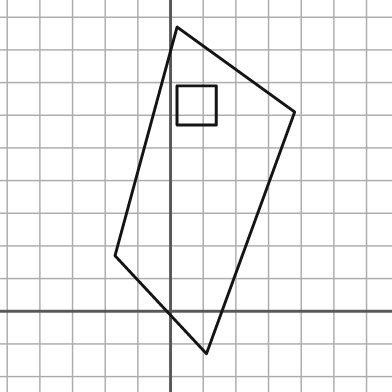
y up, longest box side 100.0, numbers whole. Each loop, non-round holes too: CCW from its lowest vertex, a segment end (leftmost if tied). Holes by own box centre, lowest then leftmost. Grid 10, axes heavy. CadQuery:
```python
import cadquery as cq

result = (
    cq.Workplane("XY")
    .moveTo(11.0, -13.0)
    .lineTo(38.0, 61.0)
    .lineTo(2.0, 87.0)
    .lineTo(-17.0, 17.0)
    .close()
    .moveTo(2.0, 57.0)
    .lineTo(14.0, 57.0)
    .lineTo(14.0, 69.0)
    .lineTo(2.0, 69.0)
    .close()
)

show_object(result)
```